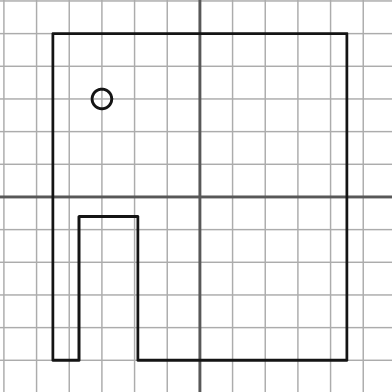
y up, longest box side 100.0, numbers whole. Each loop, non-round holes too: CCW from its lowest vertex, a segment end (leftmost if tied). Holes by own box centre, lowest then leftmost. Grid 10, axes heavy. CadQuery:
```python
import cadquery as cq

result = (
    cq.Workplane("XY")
    .moveTo(-45.0, -50.0)
    .lineTo(-37.0, -50.0)
    .lineTo(-37.0, -6.0)
    .lineTo(-19.0, -6.0)
    .lineTo(-19.0, -50.0)
    .lineTo(45.0, -50.0)
    .lineTo(45.0, 50.0)
    .lineTo(-45.0, 50.0)
    .close()
    .moveTo(-30.0, 30.0)
    .circle(3.0)
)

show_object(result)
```